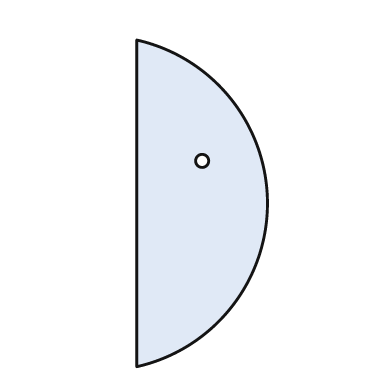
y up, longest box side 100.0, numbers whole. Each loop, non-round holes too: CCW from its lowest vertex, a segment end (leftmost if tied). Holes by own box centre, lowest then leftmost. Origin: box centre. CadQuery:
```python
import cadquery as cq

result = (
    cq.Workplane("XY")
    .moveTo(-20.0, -50.0)
    .threePointArc((20.0, 0.0), (-20.0, 50.0))
    .close()
    .moveTo(0.0, 13.0)
    .circle(2.0)
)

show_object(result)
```